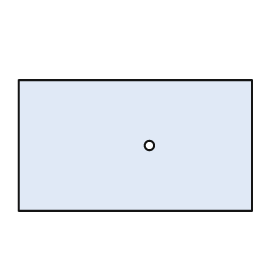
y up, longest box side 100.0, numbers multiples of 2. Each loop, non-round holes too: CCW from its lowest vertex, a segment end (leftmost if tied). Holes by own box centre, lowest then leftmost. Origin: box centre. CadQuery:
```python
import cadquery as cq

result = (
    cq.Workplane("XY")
    .moveTo(-50.0, -28.0)
    .lineTo(50.0, -28.0)
    .lineTo(50.0, 28.0)
    .lineTo(-50.0, 28.0)
    .close()
    .moveTo(6.0, 0.0)
    .circle(2.0)
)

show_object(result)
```